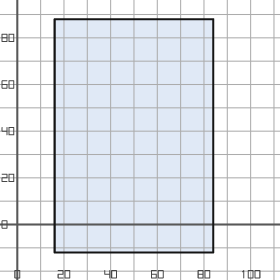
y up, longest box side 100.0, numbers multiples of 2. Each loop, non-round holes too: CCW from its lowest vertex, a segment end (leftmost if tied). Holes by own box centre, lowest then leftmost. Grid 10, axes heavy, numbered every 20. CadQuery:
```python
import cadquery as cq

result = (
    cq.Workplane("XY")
    .moveTo(16.0, -12.0)
    .lineTo(84.0, -12.0)
    .lineTo(84.0, 88.0)
    .lineTo(16.0, 88.0)
    .close()
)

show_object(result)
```